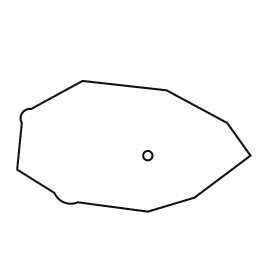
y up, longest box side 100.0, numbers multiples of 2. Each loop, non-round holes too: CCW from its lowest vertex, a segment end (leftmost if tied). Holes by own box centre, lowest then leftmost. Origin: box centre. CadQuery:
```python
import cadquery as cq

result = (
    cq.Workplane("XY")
    .moveTo(6.0, -28.0)
    .lineTo(26.0, -22.0)
    .lineTo(50.0, -4.0)
    .lineTo(40.0, 10.0)
    .lineTo(14.0, 24.0)
    .lineTo(-22.0, 28.0)
    .lineTo(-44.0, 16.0)
    .threePointArc((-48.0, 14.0), (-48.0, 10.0))
    .lineTo(-50.0, -10.0)
    .lineTo(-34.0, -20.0)
    .threePointArc((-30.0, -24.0), (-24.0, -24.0))
    .close()
    .moveTo(6.0, -4.0)
    .circle(2.0)
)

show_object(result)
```